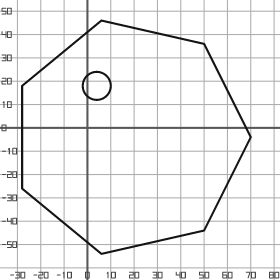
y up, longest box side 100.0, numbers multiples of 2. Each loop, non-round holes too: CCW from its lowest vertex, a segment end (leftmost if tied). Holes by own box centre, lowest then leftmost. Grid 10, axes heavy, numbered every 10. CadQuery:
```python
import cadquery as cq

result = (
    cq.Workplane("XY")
    .moveTo(6.0, -54.0)
    .lineTo(50.0, -44.0)
    .lineTo(70.0, -4.0)
    .lineTo(50.0, 36.0)
    .lineTo(6.0, 46.0)
    .lineTo(-28.0, 18.0)
    .lineTo(-28.0, -26.0)
    .close()
    .moveTo(4.0, 18.0)
    .circle(6.0)
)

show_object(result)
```